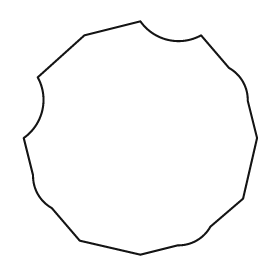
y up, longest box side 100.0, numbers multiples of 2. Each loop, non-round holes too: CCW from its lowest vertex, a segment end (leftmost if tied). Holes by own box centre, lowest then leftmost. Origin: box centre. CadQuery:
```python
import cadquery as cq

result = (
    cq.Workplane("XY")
    .moveTo(0.0, -50.0)
    .lineTo(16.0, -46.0)
    .threePointArc((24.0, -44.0), (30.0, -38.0))
    .lineTo(44.0, -26.0)
    .lineTo(50.0, 0.0)
    .lineTo(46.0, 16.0)
    .threePointArc((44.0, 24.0), (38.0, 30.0))
    .lineTo(26.0, 44.0)
    .threePointArc((12.0, 42.0), (0.0, 50.0))
    .lineTo(-24.0, 44.0)
    .lineTo(-44.0, 26.0)
    .threePointArc((-42.0, 12.0), (-50.0, 0.0))
    .lineTo(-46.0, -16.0)
    .threePointArc((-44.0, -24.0), (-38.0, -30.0))
    .lineTo(-26.0, -44.0)
    .close()
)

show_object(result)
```